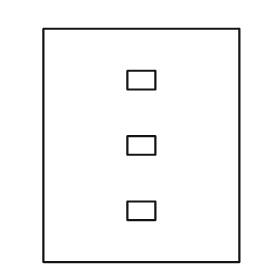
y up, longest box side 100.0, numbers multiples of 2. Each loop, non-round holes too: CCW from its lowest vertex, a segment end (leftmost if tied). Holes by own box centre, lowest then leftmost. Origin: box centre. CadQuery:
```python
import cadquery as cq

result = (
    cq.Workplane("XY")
    .moveTo(-42.0, -50.0)
    .lineTo(42.0, -50.0)
    .lineTo(42.0, 50.0)
    .lineTo(-42.0, 50.0)
    .close()
    .moveTo(-6.0, -32.0)
    .lineTo(6.0, -32.0)
    .lineTo(6.0, -24.0)
    .lineTo(-6.0, -24.0)
    .close()
    .moveTo(-6.0, -4.0)
    .lineTo(6.0, -4.0)
    .lineTo(6.0, 4.0)
    .lineTo(-6.0, 4.0)
    .close()
    .moveTo(-6.0, 24.0)
    .lineTo(6.0, 24.0)
    .lineTo(6.0, 32.0)
    .lineTo(-6.0, 32.0)
    .close()
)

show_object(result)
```